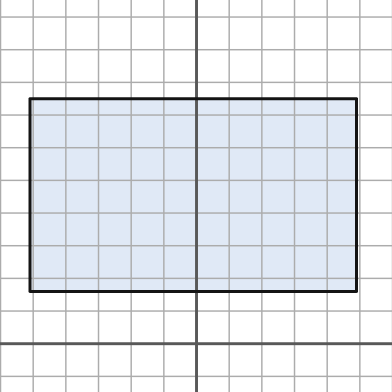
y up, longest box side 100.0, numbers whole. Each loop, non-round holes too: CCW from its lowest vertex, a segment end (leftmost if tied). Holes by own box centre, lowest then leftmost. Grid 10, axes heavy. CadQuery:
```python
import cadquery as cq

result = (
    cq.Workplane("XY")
    .moveTo(-51.0, 16.0)
    .lineTo(49.0, 16.0)
    .lineTo(49.0, 75.0)
    .lineTo(-51.0, 75.0)
    .close()
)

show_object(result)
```